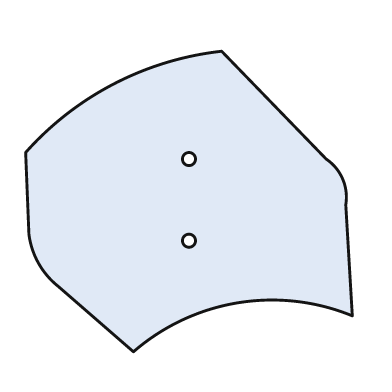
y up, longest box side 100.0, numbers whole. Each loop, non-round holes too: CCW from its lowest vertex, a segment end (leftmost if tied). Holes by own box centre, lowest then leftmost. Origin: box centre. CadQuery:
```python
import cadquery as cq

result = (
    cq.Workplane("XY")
    .moveTo(-17.0, -46.0)
    .threePointArc((15.0, -31.0), (50.0, -35.0))
    .lineTo(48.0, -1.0)
    .threePointArc((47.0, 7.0), (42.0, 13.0))
    .lineTo(10.0, 46.0)
    .threePointArc((-23.0, 36.0), (-50.0, 15.0))
    .lineTo(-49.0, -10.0)
    .threePointArc((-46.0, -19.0), (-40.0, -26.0))
    .close()
    .moveTo(0.0, -12.0)
    .circle(2.0)
    .moveTo(0.0, 13.0)
    .circle(2.0)
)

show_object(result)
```